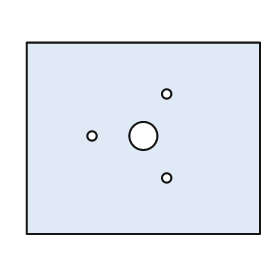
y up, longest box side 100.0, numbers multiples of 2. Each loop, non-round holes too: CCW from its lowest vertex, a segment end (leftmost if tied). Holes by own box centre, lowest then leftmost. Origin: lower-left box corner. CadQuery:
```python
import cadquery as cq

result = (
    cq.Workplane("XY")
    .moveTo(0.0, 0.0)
    .lineTo(100.0, 0.0)
    .lineTo(100.0, 82.0)
    .lineTo(0.0, 82.0)
    .close()
    .moveTo(60.0, 24.0)
    .circle(2.0)
    .moveTo(28.0, 42.0)
    .circle(2.0)
    .moveTo(50.0, 42.0)
    .circle(6.0)
    .moveTo(60.0, 60.0)
    .circle(2.0)
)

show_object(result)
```